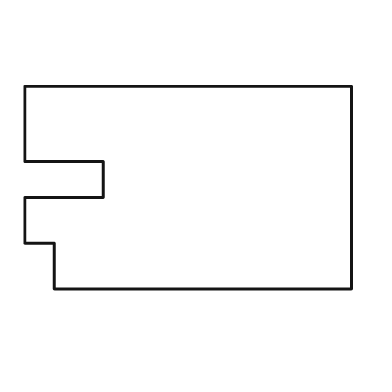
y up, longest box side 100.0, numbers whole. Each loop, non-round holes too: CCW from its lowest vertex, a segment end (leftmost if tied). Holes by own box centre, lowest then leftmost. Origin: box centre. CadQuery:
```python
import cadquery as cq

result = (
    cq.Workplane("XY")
    .moveTo(-41.0, -31.0)
    .lineTo(50.0, -31.0)
    .lineTo(50.0, 31.0)
    .lineTo(-50.0, 31.0)
    .lineTo(-50.0, 8.0)
    .lineTo(-26.0, 8.0)
    .lineTo(-26.0, -3.0)
    .lineTo(-50.0, -3.0)
    .lineTo(-50.0, -17.0)
    .lineTo(-41.0, -17.0)
    .close()
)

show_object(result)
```